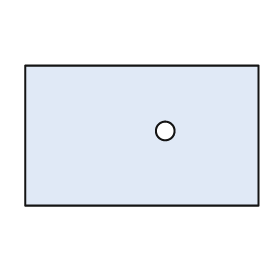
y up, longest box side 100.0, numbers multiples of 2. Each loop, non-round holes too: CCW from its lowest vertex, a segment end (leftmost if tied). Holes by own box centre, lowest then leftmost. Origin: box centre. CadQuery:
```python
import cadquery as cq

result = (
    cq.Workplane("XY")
    .moveTo(-50.0, -30.0)
    .lineTo(50.0, -30.0)
    .lineTo(50.0, 30.0)
    .lineTo(-50.0, 30.0)
    .close()
    .moveTo(10.0, 2.0)
    .circle(4.0)
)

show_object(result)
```